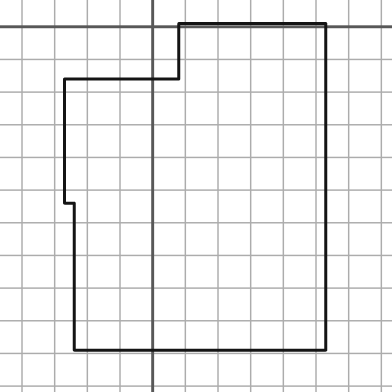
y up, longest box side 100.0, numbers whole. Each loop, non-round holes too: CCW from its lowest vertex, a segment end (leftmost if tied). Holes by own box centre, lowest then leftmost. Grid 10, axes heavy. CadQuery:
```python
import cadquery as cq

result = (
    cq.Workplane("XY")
    .moveTo(-24.0, -99.0)
    .lineTo(53.0, -99.0)
    .lineTo(53.0, 1.0)
    .lineTo(8.0, 1.0)
    .lineTo(8.0, -16.0)
    .lineTo(-27.0, -16.0)
    .lineTo(-27.0, -54.0)
    .lineTo(-24.0, -54.0)
    .close()
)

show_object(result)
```